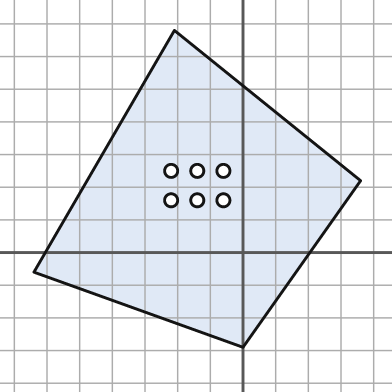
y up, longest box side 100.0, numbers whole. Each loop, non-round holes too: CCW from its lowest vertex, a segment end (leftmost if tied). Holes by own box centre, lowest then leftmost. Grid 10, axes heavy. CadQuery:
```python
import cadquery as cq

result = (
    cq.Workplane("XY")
    .moveTo(0.0, -29.0)
    .lineTo(36.0, 22.0)
    .lineTo(-21.0, 68.0)
    .lineTo(-64.0, -6.0)
    .close()
    .moveTo(-22.0, 16.0)
    .circle(2.0)
    .moveTo(-14.0, 16.0)
    .circle(2.0)
    .moveTo(-6.0, 16.0)
    .circle(2.0)
    .moveTo(-22.0, 25.0)
    .circle(2.0)
    .moveTo(-14.0, 25.0)
    .circle(2.0)
    .moveTo(-6.0, 25.0)
    .circle(2.0)
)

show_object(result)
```